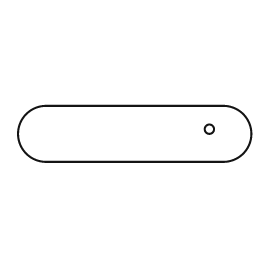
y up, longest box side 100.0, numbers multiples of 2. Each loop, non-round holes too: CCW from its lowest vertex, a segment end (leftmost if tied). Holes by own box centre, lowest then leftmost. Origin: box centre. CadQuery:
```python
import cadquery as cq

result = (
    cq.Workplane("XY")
    .moveTo(-38.0, -12.0)
    .lineTo(38.0, -12.0)
    .threePointArc((50.0, 0.0), (38.0, 12.0))
    .lineTo(-38.0, 12.0)
    .threePointArc((-50.0, 0.0), (-38.0, -12.0))
    .close()
    .moveTo(32.0, 2.0)
    .circle(2.0)
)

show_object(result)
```